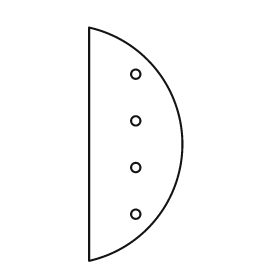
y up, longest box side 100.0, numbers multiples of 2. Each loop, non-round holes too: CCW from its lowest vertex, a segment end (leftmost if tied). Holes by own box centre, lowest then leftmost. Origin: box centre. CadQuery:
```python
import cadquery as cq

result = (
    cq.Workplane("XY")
    .moveTo(-20.0, -50.0)
    .threePointArc((20.0, 0.0), (-20.0, 50.0))
    .close()
    .moveTo(0.0, -30.0)
    .circle(2.0)
    .moveTo(0.0, -10.0)
    .circle(2.0)
    .moveTo(0.0, 10.0)
    .circle(2.0)
    .moveTo(0.0, 30.0)
    .circle(2.0)
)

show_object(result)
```